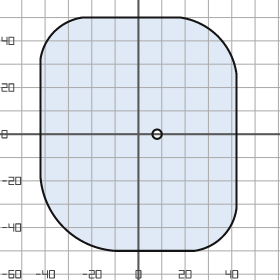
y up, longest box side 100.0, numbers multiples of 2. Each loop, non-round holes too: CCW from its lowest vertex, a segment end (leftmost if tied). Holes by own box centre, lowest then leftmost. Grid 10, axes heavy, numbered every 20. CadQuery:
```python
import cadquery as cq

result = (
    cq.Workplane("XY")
    .moveTo(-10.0, -50.0)
    .lineTo(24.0, -50.0)
    .threePointArc((36.0, -44.0), (42.0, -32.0))
    .lineTo(42.0, 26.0)
    .threePointArc((34.0, 42.0), (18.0, 50.0))
    .lineTo(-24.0, 50.0)
    .threePointArc((-36.0, 44.0), (-42.0, 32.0))
    .lineTo(-42.0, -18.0)
    .threePointArc((-32.0, -40.0), (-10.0, -50.0))
    .close()
    .moveTo(8.0, 0.0)
    .circle(2.0)
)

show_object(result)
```